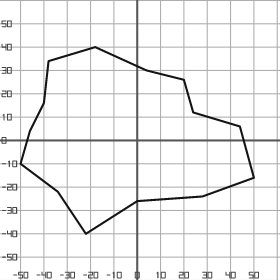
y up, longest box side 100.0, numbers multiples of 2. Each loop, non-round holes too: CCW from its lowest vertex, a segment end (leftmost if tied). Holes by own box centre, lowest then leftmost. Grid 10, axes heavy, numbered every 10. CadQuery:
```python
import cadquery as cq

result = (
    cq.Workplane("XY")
    .moveTo(-22.0, -40.0)
    .lineTo(0.0, -26.0)
    .lineTo(28.0, -24.0)
    .lineTo(50.0, -16.0)
    .lineTo(44.0, 6.0)
    .lineTo(24.0, 12.0)
    .lineTo(20.0, 26.0)
    .lineTo(4.0, 30.0)
    .lineTo(-18.0, 40.0)
    .lineTo(-38.0, 34.0)
    .lineTo(-40.0, 16.0)
    .lineTo(-46.0, 4.0)
    .lineTo(-50.0, -10.0)
    .lineTo(-34.0, -22.0)
    .close()
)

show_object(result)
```